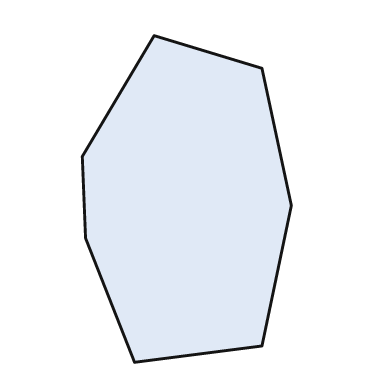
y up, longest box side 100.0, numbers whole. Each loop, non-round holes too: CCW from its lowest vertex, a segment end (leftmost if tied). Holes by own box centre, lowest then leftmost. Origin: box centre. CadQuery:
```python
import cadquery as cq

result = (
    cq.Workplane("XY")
    .moveTo(-16.0, -50.0)
    .lineTo(23.0, -45.0)
    .lineTo(32.0, -2.0)
    .lineTo(23.0, 40.0)
    .lineTo(-10.0, 50.0)
    .lineTo(-32.0, 13.0)
    .lineTo(-31.0, -12.0)
    .close()
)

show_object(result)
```